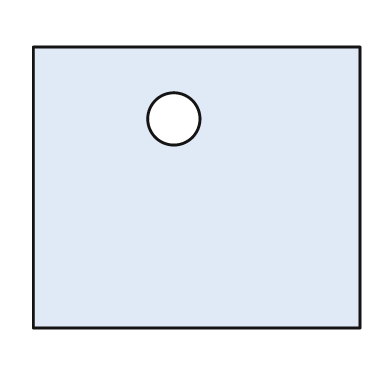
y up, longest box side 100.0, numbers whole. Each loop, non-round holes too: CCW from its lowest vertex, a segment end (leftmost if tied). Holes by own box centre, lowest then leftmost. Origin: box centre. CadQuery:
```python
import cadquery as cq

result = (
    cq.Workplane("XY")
    .moveTo(-50.0, -43.0)
    .lineTo(50.0, -43.0)
    .lineTo(50.0, 43.0)
    .lineTo(-50.0, 43.0)
    .close()
    .moveTo(-7.0, 21.0)
    .circle(8.0)
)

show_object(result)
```